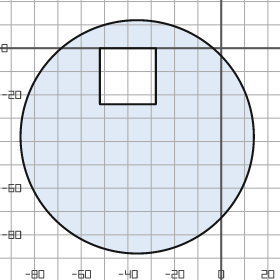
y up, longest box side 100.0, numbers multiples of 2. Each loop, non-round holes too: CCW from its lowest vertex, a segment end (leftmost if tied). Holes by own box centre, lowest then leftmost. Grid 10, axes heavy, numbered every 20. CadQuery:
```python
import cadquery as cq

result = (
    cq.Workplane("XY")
    .moveTo(-36.0, -38.0)
    .circle(50.0)
    .moveTo(-52.0, -24.0)
    .lineTo(-28.0, -24.0)
    .lineTo(-28.0, 0.0)
    .lineTo(-52.0, 0.0)
    .close()
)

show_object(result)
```